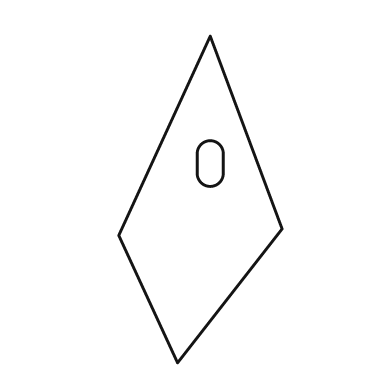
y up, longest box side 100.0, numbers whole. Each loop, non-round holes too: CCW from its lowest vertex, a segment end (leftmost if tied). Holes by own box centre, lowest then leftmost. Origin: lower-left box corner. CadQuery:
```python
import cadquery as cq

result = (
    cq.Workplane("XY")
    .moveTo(18.0, 0.0)
    .lineTo(50.0, 41.0)
    .lineTo(28.0, 100.0)
    .lineTo(0.0, 39.0)
    .close()
    .moveTo(24.0, 58.0)
    .threePointArc((28.0, 54.0), (32.0, 58.0))
    .lineTo(32.0, 64.0)
    .threePointArc((28.0, 68.0), (24.0, 64.0))
    .close()
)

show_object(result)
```